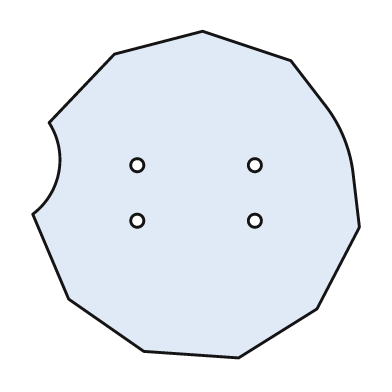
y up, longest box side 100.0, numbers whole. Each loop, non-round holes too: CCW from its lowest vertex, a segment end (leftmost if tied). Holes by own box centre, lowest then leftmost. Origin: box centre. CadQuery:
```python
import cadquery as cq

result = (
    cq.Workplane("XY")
    .moveTo(13.0, -50.0)
    .lineTo(37.0, -35.0)
    .lineTo(50.0, -10.0)
    .lineTo(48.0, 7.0)
    .threePointArc((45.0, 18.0), (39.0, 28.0))
    .lineTo(29.0, 41.0)
    .lineTo(2.0, 50.0)
    .lineTo(-25.0, 43.0)
    .lineTo(-45.0, 22.0)
    .threePointArc((-42.0, 7.0), (-50.0, -6.0))
    .lineTo(-39.0, -32.0)
    .lineTo(-16.0, -48.0)
    .close()
    .moveTo(-18.0, -8.0)
    .circle(2.0)
    .moveTo(18.0, -8.0)
    .circle(2.0)
    .moveTo(-18.0, 9.0)
    .circle(2.0)
    .moveTo(18.0, 9.0)
    .circle(2.0)
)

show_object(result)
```